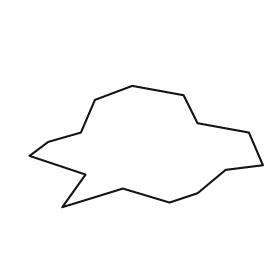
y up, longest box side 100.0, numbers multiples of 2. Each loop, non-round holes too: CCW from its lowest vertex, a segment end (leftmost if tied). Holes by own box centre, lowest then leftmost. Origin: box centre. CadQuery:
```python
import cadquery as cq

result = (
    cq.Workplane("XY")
    .moveTo(-36.0, -26.0)
    .lineTo(-10.0, -18.0)
    .lineTo(10.0, -24.0)
    .lineTo(22.0, -20.0)
    .lineTo(34.0, -10.0)
    .lineTo(50.0, -8.0)
    .lineTo(44.0, 6.0)
    .lineTo(22.0, 10.0)
    .lineTo(16.0, 22.0)
    .lineTo(-6.0, 26.0)
    .lineTo(-22.0, 20.0)
    .lineTo(-28.0, 6.0)
    .lineTo(-42.0, 2.0)
    .lineTo(-50.0, -4.0)
    .lineTo(-26.0, -12.0)
    .close()
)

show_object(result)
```